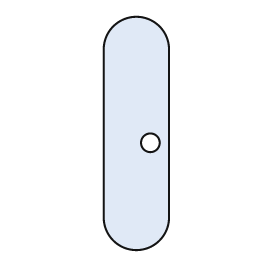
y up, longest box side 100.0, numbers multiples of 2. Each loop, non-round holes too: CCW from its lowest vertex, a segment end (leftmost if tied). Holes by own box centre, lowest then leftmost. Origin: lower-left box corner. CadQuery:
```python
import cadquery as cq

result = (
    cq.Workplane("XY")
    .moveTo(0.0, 14.0)
    .threePointArc((14.0, 0.0), (28.0, 14.0))
    .lineTo(28.0, 86.0)
    .threePointArc((14.0, 100.0), (0.0, 86.0))
    .close()
    .moveTo(20.0, 46.0)
    .circle(4.0)
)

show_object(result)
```